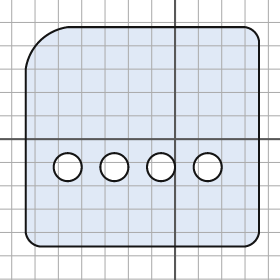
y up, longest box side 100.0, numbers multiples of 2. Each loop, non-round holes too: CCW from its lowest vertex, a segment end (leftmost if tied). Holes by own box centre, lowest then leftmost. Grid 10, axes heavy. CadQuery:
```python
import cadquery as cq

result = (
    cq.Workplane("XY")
    .moveTo(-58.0, -46.0)
    .lineTo(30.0, -46.0)
    .threePointArc((34.0, -44.0), (36.0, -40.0))
    .lineTo(36.0, 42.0)
    .threePointArc((34.0, 46.0), (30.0, 48.0))
    .lineTo(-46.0, 48.0)
    .threePointArc((-58.0, 42.0), (-64.0, 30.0))
    .lineTo(-64.0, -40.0)
    .threePointArc((-62.0, -44.0), (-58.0, -46.0))
    .close()
    .moveTo(-46.0, -12.0)
    .circle(6.0)
    .moveTo(-26.0, -12.0)
    .circle(6.0)
    .moveTo(-6.0, -12.0)
    .circle(6.0)
    .moveTo(14.0, -12.0)
    .circle(6.0)
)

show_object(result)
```